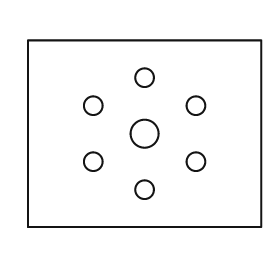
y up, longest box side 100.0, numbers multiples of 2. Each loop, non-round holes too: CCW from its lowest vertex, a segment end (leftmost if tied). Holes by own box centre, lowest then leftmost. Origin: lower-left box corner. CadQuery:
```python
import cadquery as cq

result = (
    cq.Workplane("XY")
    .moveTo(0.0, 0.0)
    .lineTo(100.0, 0.0)
    .lineTo(100.0, 80.0)
    .lineTo(0.0, 80.0)
    .close()
    .moveTo(50.0, 16.0)
    .circle(4.0)
    .moveTo(28.0, 28.0)
    .circle(4.0)
    .moveTo(72.0, 28.0)
    .circle(4.0)
    .moveTo(50.0, 40.0)
    .circle(6.0)
    .moveTo(28.0, 52.0)
    .circle(4.0)
    .moveTo(72.0, 52.0)
    .circle(4.0)
    .moveTo(50.0, 64.0)
    .circle(4.0)
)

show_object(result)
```